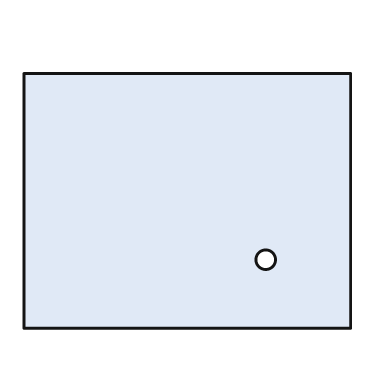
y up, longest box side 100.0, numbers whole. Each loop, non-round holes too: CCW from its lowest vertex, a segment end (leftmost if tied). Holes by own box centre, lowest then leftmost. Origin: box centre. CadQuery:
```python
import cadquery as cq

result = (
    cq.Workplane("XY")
    .moveTo(-50.0, -39.0)
    .lineTo(50.0, -39.0)
    .lineTo(50.0, 39.0)
    .lineTo(-50.0, 39.0)
    .close()
    .moveTo(24.0, -18.0)
    .circle(3.0)
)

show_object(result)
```